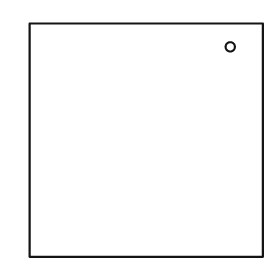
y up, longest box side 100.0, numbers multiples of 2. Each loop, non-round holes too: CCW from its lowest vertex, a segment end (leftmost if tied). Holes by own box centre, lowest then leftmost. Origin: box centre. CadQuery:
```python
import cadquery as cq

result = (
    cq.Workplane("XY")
    .moveTo(-50.0, -50.0)
    .lineTo(50.0, -50.0)
    .lineTo(50.0, 50.0)
    .lineTo(-50.0, 50.0)
    .close()
    .moveTo(36.0, 40.0)
    .circle(2.0)
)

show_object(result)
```